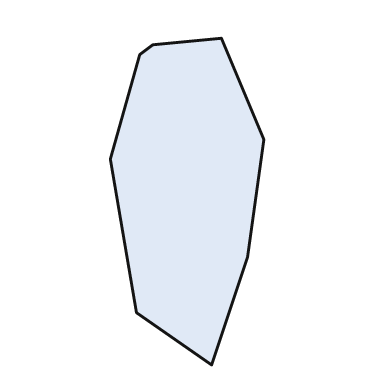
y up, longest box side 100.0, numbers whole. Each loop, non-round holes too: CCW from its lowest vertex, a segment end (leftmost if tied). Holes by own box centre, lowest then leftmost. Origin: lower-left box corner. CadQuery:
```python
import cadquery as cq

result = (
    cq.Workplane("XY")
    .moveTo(31.0, 0.0)
    .lineTo(42.0, 33.0)
    .lineTo(47.0, 69.0)
    .lineTo(34.0, 100.0)
    .lineTo(13.0, 98.0)
    .lineTo(9.0, 95.0)
    .lineTo(0.0, 63.0)
    .lineTo(8.0, 16.0)
    .close()
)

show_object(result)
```